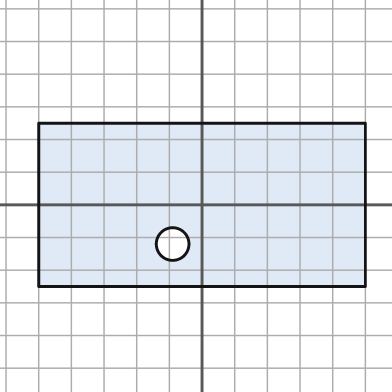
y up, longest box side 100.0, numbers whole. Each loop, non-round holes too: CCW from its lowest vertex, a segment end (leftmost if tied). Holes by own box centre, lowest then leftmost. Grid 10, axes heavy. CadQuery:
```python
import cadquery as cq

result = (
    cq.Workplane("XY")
    .moveTo(-50.0, -25.0)
    .lineTo(50.0, -25.0)
    .lineTo(50.0, 25.0)
    .lineTo(-50.0, 25.0)
    .close()
    .moveTo(-9.0, -12.0)
    .circle(5.0)
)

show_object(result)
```